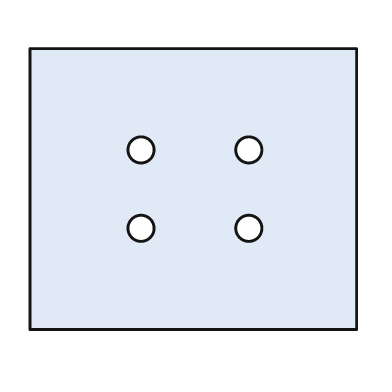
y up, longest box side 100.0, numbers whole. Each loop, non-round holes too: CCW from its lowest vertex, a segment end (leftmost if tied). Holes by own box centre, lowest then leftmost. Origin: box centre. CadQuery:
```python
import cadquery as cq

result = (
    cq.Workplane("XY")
    .moveTo(-50.0, -43.0)
    .lineTo(50.0, -43.0)
    .lineTo(50.0, 43.0)
    .lineTo(-50.0, 43.0)
    .close()
    .moveTo(-16.0, -12.0)
    .circle(4.0)
    .moveTo(17.0, -12.0)
    .circle(4.0)
    .moveTo(-16.0, 12.0)
    .circle(4.0)
    .moveTo(17.0, 12.0)
    .circle(4.0)
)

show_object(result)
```